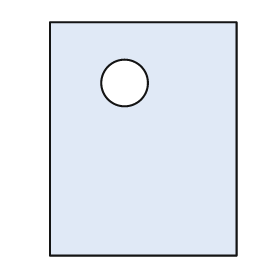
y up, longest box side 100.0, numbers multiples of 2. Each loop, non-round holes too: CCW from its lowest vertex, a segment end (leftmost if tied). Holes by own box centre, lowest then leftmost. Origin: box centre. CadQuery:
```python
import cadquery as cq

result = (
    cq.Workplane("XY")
    .moveTo(-40.0, -50.0)
    .lineTo(40.0, -50.0)
    .lineTo(40.0, 50.0)
    .lineTo(-40.0, 50.0)
    .close()
    .moveTo(-8.0, 24.0)
    .circle(10.0)
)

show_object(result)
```